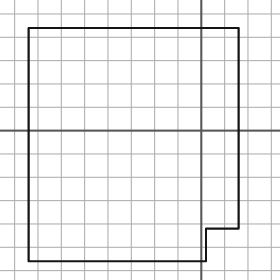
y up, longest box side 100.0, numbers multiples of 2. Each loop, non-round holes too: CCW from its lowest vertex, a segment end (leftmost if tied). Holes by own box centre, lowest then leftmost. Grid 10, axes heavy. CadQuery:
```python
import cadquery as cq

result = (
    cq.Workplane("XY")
    .moveTo(-74.0, -56.0)
    .lineTo(2.0, -56.0)
    .lineTo(2.0, -42.0)
    .lineTo(16.0, -42.0)
    .lineTo(16.0, 44.0)
    .lineTo(-74.0, 44.0)
    .close()
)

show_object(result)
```